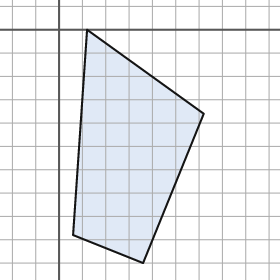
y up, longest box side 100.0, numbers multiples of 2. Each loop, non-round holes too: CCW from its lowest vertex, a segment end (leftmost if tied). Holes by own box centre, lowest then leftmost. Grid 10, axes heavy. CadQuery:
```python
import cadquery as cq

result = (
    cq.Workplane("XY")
    .moveTo(36.0, -100.0)
    .lineTo(62.0, -36.0)
    .lineTo(12.0, 0.0)
    .lineTo(6.0, -88.0)
    .close()
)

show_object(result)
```